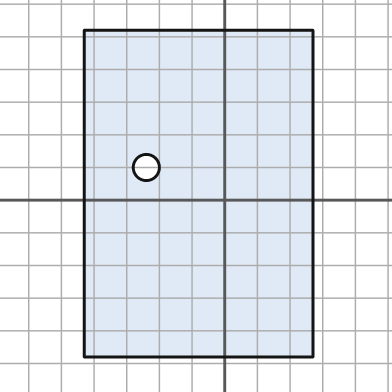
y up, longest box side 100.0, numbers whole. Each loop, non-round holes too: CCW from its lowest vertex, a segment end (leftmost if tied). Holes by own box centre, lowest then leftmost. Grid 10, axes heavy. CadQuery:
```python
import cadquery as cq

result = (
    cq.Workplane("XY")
    .moveTo(-43.0, -48.0)
    .lineTo(27.0, -48.0)
    .lineTo(27.0, 52.0)
    .lineTo(-43.0, 52.0)
    .close()
    .moveTo(-24.0, 10.0)
    .circle(4.0)
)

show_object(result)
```